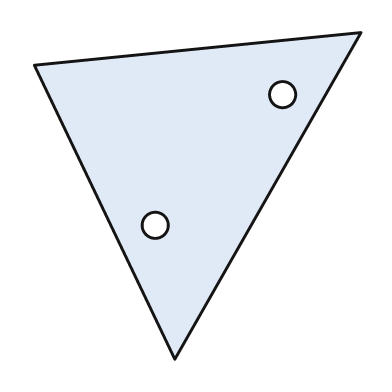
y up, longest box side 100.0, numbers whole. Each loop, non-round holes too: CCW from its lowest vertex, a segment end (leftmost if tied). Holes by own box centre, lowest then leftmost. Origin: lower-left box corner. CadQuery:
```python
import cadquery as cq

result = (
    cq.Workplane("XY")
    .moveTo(43.0, 0.0)
    .lineTo(100.0, 100.0)
    .lineTo(0.0, 90.0)
    .close()
    .moveTo(37.0, 41.0)
    .circle(4.0)
    .moveTo(76.0, 81.0)
    .circle(4.0)
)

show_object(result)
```